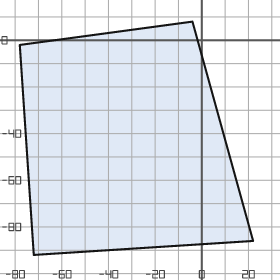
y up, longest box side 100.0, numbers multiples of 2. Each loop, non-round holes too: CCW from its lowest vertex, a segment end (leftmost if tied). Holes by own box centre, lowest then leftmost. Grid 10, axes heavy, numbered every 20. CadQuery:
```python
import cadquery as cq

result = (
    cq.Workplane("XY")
    .moveTo(-72.0, -92.0)
    .lineTo(22.0, -86.0)
    .lineTo(-4.0, 8.0)
    .lineTo(-78.0, -2.0)
    .close()
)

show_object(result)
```